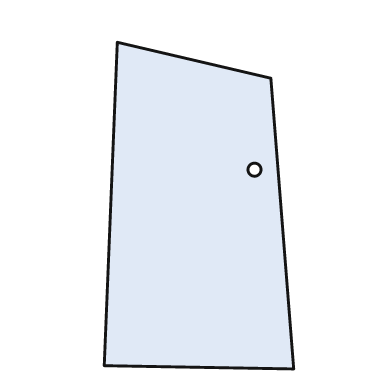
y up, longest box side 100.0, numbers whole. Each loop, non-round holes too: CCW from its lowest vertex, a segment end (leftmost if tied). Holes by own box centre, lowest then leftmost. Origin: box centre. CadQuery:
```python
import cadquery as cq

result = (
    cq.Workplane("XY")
    .moveTo(29.0, -50.0)
    .lineTo(22.0, 39.0)
    .lineTo(-25.0, 50.0)
    .lineTo(-29.0, -49.0)
    .close()
    .moveTo(17.0, 11.0)
    .circle(2.0)
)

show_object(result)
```